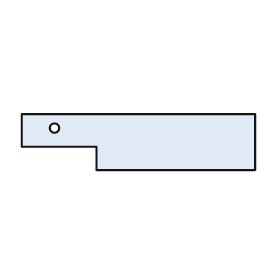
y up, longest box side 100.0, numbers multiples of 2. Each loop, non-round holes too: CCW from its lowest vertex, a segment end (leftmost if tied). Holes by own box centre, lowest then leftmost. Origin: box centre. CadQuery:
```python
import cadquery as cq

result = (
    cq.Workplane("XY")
    .moveTo(-18.0, -12.0)
    .lineTo(50.0, -12.0)
    .lineTo(50.0, 12.0)
    .lineTo(-50.0, 12.0)
    .lineTo(-50.0, -2.0)
    .lineTo(-18.0, -2.0)
    .close()
    .moveTo(-36.0, 6.0)
    .circle(2.0)
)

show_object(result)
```